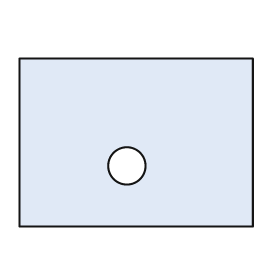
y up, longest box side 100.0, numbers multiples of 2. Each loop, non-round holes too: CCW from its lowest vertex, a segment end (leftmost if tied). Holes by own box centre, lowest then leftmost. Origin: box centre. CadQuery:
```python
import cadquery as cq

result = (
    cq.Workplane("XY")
    .moveTo(-50.0, -36.0)
    .lineTo(50.0, -36.0)
    .lineTo(50.0, 36.0)
    .lineTo(-50.0, 36.0)
    .close()
    .moveTo(-4.0, -10.0)
    .circle(8.0)
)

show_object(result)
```